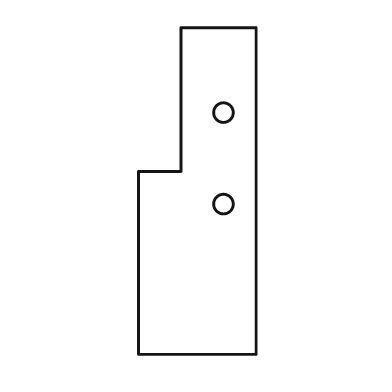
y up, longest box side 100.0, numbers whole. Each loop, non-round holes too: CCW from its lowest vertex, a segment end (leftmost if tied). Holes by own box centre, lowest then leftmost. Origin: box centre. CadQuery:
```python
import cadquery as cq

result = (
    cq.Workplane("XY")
    .moveTo(-18.0, -50.0)
    .lineTo(18.0, -50.0)
    .lineTo(18.0, 50.0)
    .lineTo(-5.0, 50.0)
    .lineTo(-5.0, 6.0)
    .lineTo(-18.0, 6.0)
    .close()
    .moveTo(8.0, -4.0)
    .circle(3.0)
    .moveTo(8.0, 24.0)
    .circle(3.0)
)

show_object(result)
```